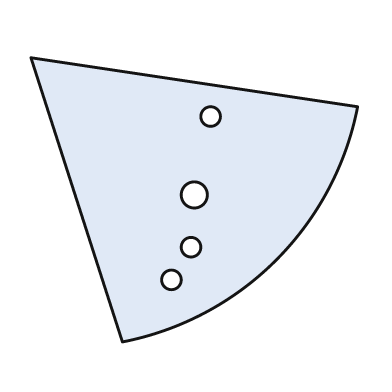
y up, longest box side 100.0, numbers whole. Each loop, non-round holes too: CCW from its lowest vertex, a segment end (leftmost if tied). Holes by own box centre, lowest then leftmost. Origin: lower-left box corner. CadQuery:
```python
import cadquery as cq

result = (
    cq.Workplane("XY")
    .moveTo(28.0, 0.0)
    .threePointArc((75.0, 25.0), (100.0, 72.0))
    .lineTo(0.0, 87.0)
    .close()
    .moveTo(43.0, 19.0)
    .circle(3.0)
    .moveTo(49.0, 29.0)
    .circle(3.0)
    .moveTo(50.0, 45.0)
    .circle(4.0)
    .moveTo(55.0, 69.0)
    .circle(3.0)
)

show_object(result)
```